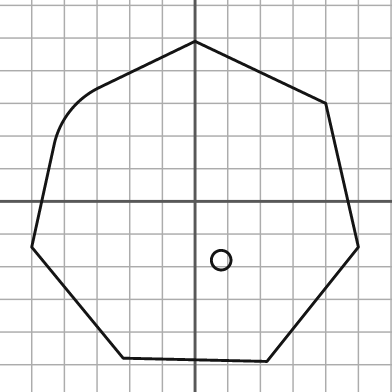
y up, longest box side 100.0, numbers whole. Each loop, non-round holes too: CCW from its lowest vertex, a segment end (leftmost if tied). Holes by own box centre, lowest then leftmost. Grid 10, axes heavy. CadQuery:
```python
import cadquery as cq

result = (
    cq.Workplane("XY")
    .moveTo(22.0, -49.0)
    .lineTo(50.0, -14.0)
    .lineTo(40.0, 30.0)
    .lineTo(0.0, 49.0)
    .lineTo(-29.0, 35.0)
    .threePointArc((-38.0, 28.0), (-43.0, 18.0))
    .lineTo(-50.0, -14.0)
    .lineTo(-22.0, -48.0)
    .close()
    .moveTo(8.0, -18.0)
    .circle(3.0)
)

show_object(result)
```